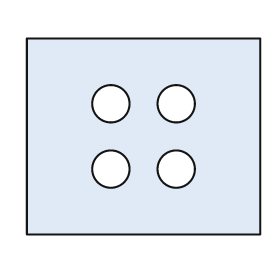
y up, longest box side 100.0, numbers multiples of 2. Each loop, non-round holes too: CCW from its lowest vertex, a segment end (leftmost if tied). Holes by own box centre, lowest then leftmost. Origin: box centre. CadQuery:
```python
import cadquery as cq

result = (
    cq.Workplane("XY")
    .moveTo(-50.0, -42.0)
    .lineTo(50.0, -42.0)
    .lineTo(50.0, 42.0)
    .lineTo(-50.0, 42.0)
    .close()
    .moveTo(-14.0, -14.0)
    .circle(8.0)
    .moveTo(14.0, -14.0)
    .circle(8.0)
    .moveTo(-14.0, 14.0)
    .circle(8.0)
    .moveTo(14.0, 14.0)
    .circle(8.0)
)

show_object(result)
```